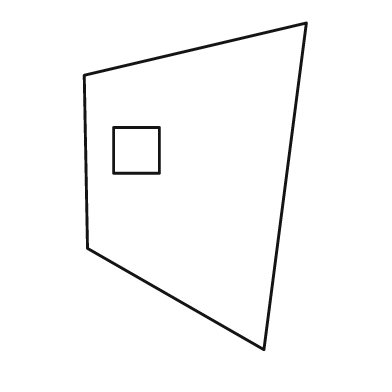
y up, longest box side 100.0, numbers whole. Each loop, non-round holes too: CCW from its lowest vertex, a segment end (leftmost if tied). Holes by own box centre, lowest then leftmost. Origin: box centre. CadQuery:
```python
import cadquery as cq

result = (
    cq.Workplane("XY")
    .moveTo(21.0, -50.0)
    .lineTo(34.0, 50.0)
    .lineTo(-34.0, 34.0)
    .lineTo(-33.0, -19.0)
    .close()
    .moveTo(-25.0, 4.0)
    .lineTo(-11.0, 4.0)
    .lineTo(-11.0, 18.0)
    .lineTo(-25.0, 18.0)
    .close()
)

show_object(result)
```